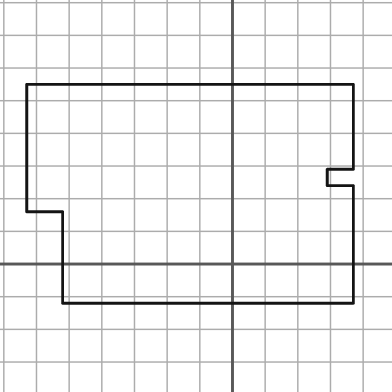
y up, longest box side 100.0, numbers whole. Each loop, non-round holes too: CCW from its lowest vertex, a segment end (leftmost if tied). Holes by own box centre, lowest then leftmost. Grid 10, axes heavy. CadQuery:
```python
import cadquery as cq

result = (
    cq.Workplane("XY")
    .moveTo(-52.0, -12.0)
    .lineTo(37.0, -12.0)
    .lineTo(37.0, 24.0)
    .lineTo(29.0, 24.0)
    .lineTo(29.0, 29.0)
    .lineTo(37.0, 29.0)
    .lineTo(37.0, 55.0)
    .lineTo(-63.0, 55.0)
    .lineTo(-63.0, 16.0)
    .lineTo(-52.0, 16.0)
    .close()
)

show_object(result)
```